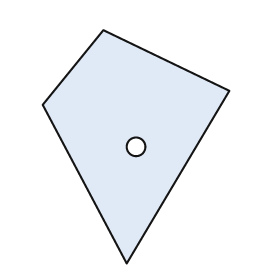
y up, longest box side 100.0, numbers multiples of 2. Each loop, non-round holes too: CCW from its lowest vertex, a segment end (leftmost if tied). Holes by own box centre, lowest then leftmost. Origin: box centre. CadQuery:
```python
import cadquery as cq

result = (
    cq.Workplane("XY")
    .moveTo(-4.0, -50.0)
    .lineTo(40.0, 24.0)
    .lineTo(-14.0, 50.0)
    .lineTo(-40.0, 18.0)
    .close()
    .moveTo(0.0, 0.0)
    .circle(4.0)
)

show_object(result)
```